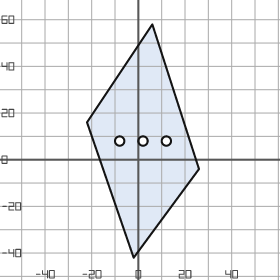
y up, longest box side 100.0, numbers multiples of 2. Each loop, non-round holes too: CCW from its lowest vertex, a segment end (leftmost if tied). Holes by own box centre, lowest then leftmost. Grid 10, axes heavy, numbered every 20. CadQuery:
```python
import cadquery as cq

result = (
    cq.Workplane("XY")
    .moveTo(-2.0, -42.0)
    .lineTo(26.0, -4.0)
    .lineTo(6.0, 58.0)
    .lineTo(-22.0, 16.0)
    .close()
    .moveTo(-8.0, 8.0)
    .circle(2.0)
    .moveTo(2.0, 8.0)
    .circle(2.0)
    .moveTo(12.0, 8.0)
    .circle(2.0)
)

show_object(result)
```